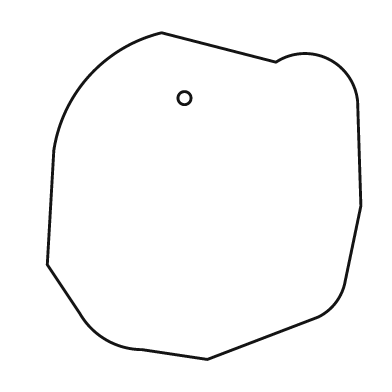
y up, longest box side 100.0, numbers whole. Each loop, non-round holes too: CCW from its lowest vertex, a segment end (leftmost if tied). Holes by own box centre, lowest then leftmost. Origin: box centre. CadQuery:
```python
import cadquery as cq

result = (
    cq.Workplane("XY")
    .moveTo(1.0, -50.0)
    .lineTo(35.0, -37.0)
    .threePointArc((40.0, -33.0), (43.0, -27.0))
    .lineTo(48.0, -3.0)
    .lineTo(47.0, 29.0)
    .threePointArc((38.0, 42.0), (22.0, 41.0))
    .lineTo(-13.0, 50.0)
    .threePointArc((-35.0, 37.0), (-46.0, 14.0))
    .lineTo(-48.0, -21.0)
    .lineTo(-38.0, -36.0)
    .threePointArc((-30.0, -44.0), (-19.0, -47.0))
    .close()
    .moveTo(-6.0, 30.0)
    .circle(2.0)
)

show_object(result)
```